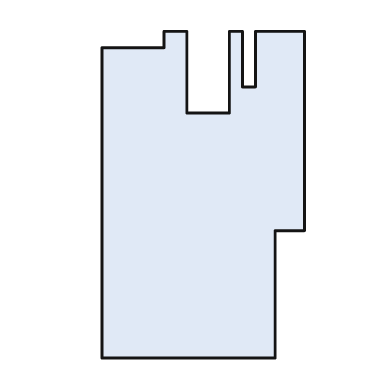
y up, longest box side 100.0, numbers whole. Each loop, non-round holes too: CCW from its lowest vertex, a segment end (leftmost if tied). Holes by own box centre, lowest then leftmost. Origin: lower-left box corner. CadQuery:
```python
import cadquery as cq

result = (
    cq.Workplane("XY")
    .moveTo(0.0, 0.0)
    .lineTo(53.0, 0.0)
    .lineTo(53.0, 39.0)
    .lineTo(62.0, 39.0)
    .lineTo(62.0, 100.0)
    .lineTo(47.0, 100.0)
    .lineTo(47.0, 83.0)
    .lineTo(43.0, 83.0)
    .lineTo(43.0, 100.0)
    .lineTo(39.0, 100.0)
    .lineTo(39.0, 75.0)
    .lineTo(26.0, 75.0)
    .lineTo(26.0, 100.0)
    .lineTo(19.0, 100.0)
    .lineTo(19.0, 95.0)
    .lineTo(0.0, 95.0)
    .close()
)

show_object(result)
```